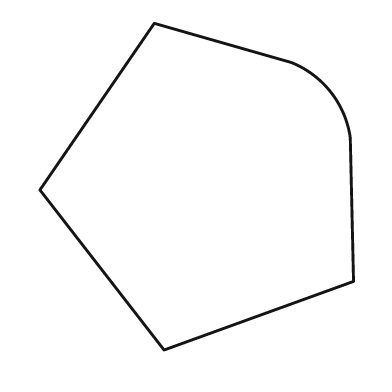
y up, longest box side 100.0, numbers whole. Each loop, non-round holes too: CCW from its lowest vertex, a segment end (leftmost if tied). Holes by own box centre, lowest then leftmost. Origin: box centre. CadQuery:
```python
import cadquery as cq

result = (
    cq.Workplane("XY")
    .moveTo(-10.0, -50.0)
    .lineTo(48.0, -29.0)
    .lineTo(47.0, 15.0)
    .threePointArc((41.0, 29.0), (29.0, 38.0))
    .lineTo(-13.0, 50.0)
    .lineTo(-48.0, -1.0)
    .close()
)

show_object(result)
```